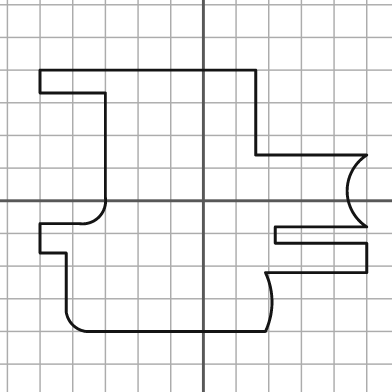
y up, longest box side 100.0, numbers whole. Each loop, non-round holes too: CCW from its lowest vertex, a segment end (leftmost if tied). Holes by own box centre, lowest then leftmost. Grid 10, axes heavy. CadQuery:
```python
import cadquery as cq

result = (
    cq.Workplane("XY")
    .moveTo(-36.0, -40.0)
    .lineTo(19.0, -40.0)
    .threePointArc((21.0, -31.0), (19.0, -22.0))
    .lineTo(50.0, -22.0)
    .lineTo(50.0, -13.0)
    .lineTo(22.0, -13.0)
    .lineTo(22.0, -8.0)
    .lineTo(50.0, -8.0)
    .threePointArc((44.0, 3.0), (50.0, 14.0))
    .lineTo(16.0, 14.0)
    .lineTo(16.0, 40.0)
    .lineTo(-50.0, 40.0)
    .lineTo(-50.0, 33.0)
    .lineTo(-30.0, 33.0)
    .lineTo(-30.0, 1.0)
    .threePointArc((-32.0, -5.0), (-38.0, -7.0))
    .lineTo(-50.0, -7.0)
    .lineTo(-50.0, -16.0)
    .lineTo(-42.0, -16.0)
    .lineTo(-42.0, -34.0)
    .threePointArc((-40.0, -38.0), (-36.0, -40.0))
    .close()
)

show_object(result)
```